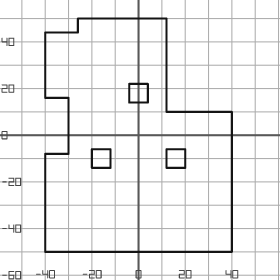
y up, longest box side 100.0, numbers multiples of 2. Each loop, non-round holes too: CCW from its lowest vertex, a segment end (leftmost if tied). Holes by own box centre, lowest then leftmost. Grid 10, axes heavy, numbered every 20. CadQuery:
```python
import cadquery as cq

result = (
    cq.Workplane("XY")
    .moveTo(-40.0, -50.0)
    .lineTo(40.0, -50.0)
    .lineTo(40.0, 10.0)
    .lineTo(12.0, 10.0)
    .lineTo(12.0, 50.0)
    .lineTo(-26.0, 50.0)
    .lineTo(-26.0, 44.0)
    .lineTo(-40.0, 44.0)
    .lineTo(-40.0, 16.0)
    .lineTo(-30.0, 16.0)
    .lineTo(-30.0, -8.0)
    .lineTo(-40.0, -8.0)
    .close()
    .moveTo(-20.0, -14.0)
    .lineTo(-12.0, -14.0)
    .lineTo(-12.0, -6.0)
    .lineTo(-20.0, -6.0)
    .close()
    .moveTo(12.0, -14.0)
    .lineTo(20.0, -14.0)
    .lineTo(20.0, -6.0)
    .lineTo(12.0, -6.0)
    .close()
    .moveTo(-4.0, 14.0)
    .lineTo(4.0, 14.0)
    .lineTo(4.0, 22.0)
    .lineTo(-4.0, 22.0)
    .close()
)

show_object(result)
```